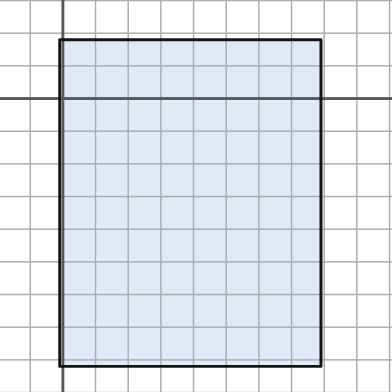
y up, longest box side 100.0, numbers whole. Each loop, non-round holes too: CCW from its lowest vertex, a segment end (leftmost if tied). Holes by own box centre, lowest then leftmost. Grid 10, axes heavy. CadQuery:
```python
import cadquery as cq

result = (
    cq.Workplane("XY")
    .moveTo(-1.0, -82.0)
    .lineTo(79.0, -82.0)
    .lineTo(79.0, 18.0)
    .lineTo(-1.0, 18.0)
    .close()
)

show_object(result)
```